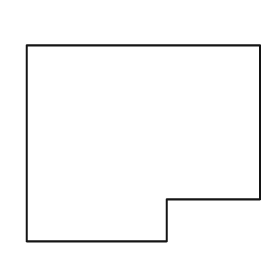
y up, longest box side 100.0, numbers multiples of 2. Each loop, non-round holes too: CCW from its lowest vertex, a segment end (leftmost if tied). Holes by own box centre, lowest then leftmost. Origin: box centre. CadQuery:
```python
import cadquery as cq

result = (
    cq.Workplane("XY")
    .moveTo(-50.0, -42.0)
    .lineTo(10.0, -42.0)
    .lineTo(10.0, -24.0)
    .lineTo(50.0, -24.0)
    .lineTo(50.0, 42.0)
    .lineTo(-50.0, 42.0)
    .close()
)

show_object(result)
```